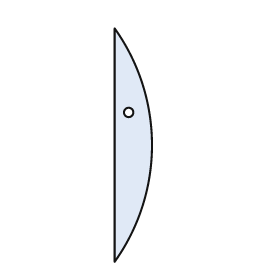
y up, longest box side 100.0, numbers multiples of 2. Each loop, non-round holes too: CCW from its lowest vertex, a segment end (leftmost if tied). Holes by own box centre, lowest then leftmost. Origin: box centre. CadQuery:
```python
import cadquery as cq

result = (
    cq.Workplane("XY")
    .moveTo(-8.0, -50.0)
    .threePointArc((8.0, 0.0), (-8.0, 50.0))
    .close()
    .moveTo(-2.0, 14.0)
    .circle(2.0)
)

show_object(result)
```